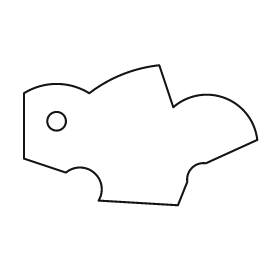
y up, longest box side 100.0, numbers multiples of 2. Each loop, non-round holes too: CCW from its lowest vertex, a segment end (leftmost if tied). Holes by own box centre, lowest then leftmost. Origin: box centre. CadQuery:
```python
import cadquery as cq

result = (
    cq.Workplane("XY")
    .moveTo(16.0, -30.0)
    .lineTo(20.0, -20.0)
    .threePointArc((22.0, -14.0), (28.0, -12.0))
    .lineTo(50.0, -2.0)
    .threePointArc((36.0, 16.0), (14.0, 12.0))
    .lineTo(8.0, 30.0)
    .threePointArc((-8.0, 26.0), (-22.0, 18.0))
    .threePointArc((-36.0, 22.0), (-50.0, 18.0))
    .lineTo(-50.0, -10.0)
    .lineTo(-32.0, -16.0)
    .threePointArc((-20.0, -16.0), (-18.0, -28.0))
    .close()
    .moveTo(-36.0, 6.0)
    .circle(4.0)
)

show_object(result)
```